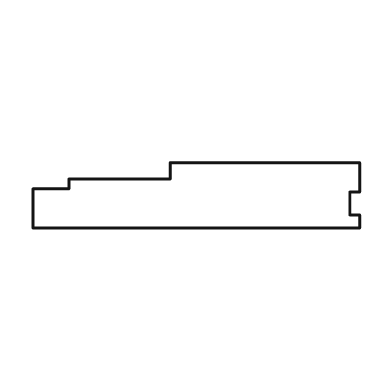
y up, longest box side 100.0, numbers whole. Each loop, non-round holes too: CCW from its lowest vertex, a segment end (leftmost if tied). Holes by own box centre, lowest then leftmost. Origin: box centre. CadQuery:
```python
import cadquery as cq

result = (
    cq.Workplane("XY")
    .moveTo(-50.0, -10.0)
    .lineTo(50.0, -10.0)
    .lineTo(50.0, -6.0)
    .lineTo(47.0, -6.0)
    .lineTo(47.0, 1.0)
    .lineTo(50.0, 1.0)
    .lineTo(50.0, 10.0)
    .lineTo(-8.0, 10.0)
    .lineTo(-8.0, 5.0)
    .lineTo(-39.0, 5.0)
    .lineTo(-39.0, 2.0)
    .lineTo(-50.0, 2.0)
    .close()
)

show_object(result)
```